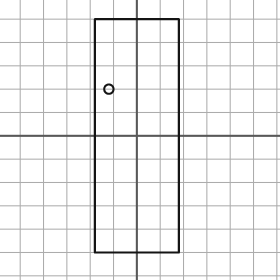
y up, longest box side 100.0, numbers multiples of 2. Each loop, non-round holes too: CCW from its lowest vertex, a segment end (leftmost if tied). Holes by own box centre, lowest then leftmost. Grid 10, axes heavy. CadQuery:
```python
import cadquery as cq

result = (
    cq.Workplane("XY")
    .moveTo(-18.0, -50.0)
    .lineTo(18.0, -50.0)
    .lineTo(18.0, 50.0)
    .lineTo(-18.0, 50.0)
    .close()
    .moveTo(-12.0, 20.0)
    .circle(2.0)
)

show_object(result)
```